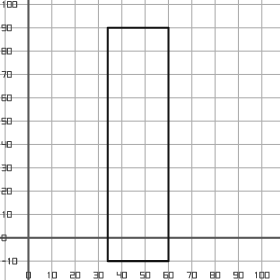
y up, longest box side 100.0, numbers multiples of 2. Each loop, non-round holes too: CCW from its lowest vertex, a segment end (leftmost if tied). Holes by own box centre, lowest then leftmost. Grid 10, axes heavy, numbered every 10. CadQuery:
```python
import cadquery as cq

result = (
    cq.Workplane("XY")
    .moveTo(34.0, -10.0)
    .lineTo(60.0, -10.0)
    .lineTo(60.0, 90.0)
    .lineTo(34.0, 90.0)
    .close()
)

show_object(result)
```